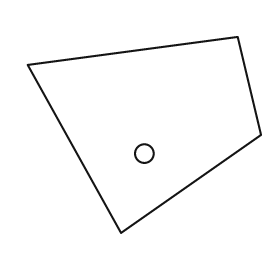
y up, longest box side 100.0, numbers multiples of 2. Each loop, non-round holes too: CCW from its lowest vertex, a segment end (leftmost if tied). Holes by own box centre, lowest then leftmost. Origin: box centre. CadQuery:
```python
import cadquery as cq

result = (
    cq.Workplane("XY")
    .moveTo(-10.0, -42.0)
    .lineTo(50.0, 0.0)
    .lineTo(40.0, 42.0)
    .lineTo(-50.0, 30.0)
    .close()
    .moveTo(0.0, -8.0)
    .circle(4.0)
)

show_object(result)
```